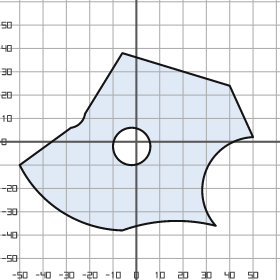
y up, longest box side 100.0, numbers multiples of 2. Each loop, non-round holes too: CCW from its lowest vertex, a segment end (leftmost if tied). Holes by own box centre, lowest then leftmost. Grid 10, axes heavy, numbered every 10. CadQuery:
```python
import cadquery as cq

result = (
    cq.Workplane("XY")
    .moveTo(-6.0, -38.0)
    .threePointArc((14.0, -34.0), (34.0, -36.0))
    .threePointArc((30.0, -12.0), (50.0, 2.0))
    .lineTo(40.0, 24.0)
    .lineTo(-6.0, 38.0)
    .lineTo(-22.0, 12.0)
    .threePointArc((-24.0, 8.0), (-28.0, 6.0))
    .lineTo(-50.0, -10.0)
    .threePointArc((-32.0, -30.0), (-6.0, -38.0))
    .close()
    .moveTo(-2.0, -2.0)
    .circle(8.0)
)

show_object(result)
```